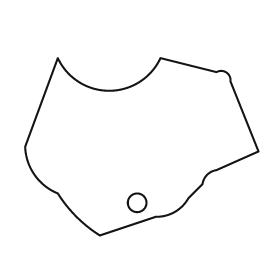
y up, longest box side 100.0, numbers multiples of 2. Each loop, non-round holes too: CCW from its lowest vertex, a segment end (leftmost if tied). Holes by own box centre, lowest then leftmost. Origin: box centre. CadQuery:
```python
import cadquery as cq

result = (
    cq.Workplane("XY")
    .moveTo(-18.0, -38.0)
    .lineTo(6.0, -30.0)
    .threePointArc((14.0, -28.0), (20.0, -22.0))
    .lineTo(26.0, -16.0)
    .threePointArc((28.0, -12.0), (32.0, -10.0))
    .lineTo(50.0, -2.0)
    .lineTo(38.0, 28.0)
    .threePointArc((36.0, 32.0), (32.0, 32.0))
    .lineTo(8.0, 38.0)
    .threePointArc((-14.0, 24.0), (-36.0, 38.0))
    .lineTo(-50.0, 0.0)
    .threePointArc((-46.0, -12.0), (-36.0, -20.0))
    .threePointArc((-28.0, -30.0), (-18.0, -38.0))
    .close()
    .moveTo(-2.0, -24.0)
    .circle(4.0)
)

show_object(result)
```